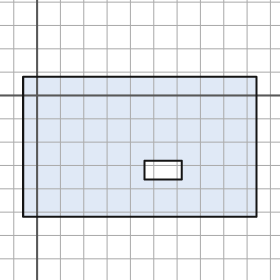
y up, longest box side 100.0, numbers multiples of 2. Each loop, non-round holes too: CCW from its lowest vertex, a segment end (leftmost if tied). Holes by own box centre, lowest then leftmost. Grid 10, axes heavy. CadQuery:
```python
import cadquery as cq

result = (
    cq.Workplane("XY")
    .moveTo(-6.0, -52.0)
    .lineTo(94.0, -52.0)
    .lineTo(94.0, 8.0)
    .lineTo(-6.0, 8.0)
    .close()
    .moveTo(46.0, -36.0)
    .lineTo(62.0, -36.0)
    .lineTo(62.0, -28.0)
    .lineTo(46.0, -28.0)
    .close()
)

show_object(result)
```